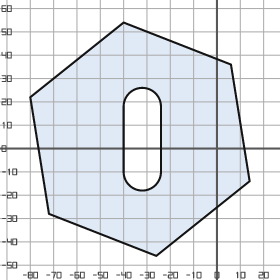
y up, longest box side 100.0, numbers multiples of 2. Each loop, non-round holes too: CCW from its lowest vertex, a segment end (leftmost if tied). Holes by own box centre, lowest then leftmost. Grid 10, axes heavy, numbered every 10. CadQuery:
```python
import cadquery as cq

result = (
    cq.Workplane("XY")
    .moveTo(-26.0, -46.0)
    .lineTo(14.0, -14.0)
    .lineTo(6.0, 36.0)
    .lineTo(-40.0, 54.0)
    .lineTo(-80.0, 22.0)
    .lineTo(-72.0, -28.0)
    .close()
    .moveTo(-40.0, -10.0)
    .threePointArc((-32.0, -18.0), (-24.0, -10.0))
    .lineTo(-24.0, 18.0)
    .threePointArc((-32.0, 26.0), (-40.0, 18.0))
    .close()
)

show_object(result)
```